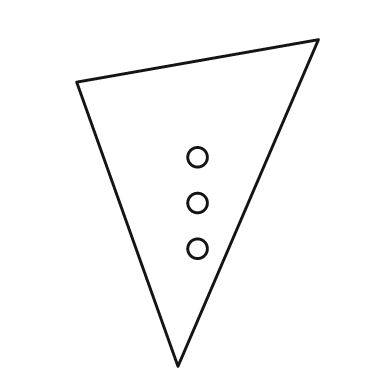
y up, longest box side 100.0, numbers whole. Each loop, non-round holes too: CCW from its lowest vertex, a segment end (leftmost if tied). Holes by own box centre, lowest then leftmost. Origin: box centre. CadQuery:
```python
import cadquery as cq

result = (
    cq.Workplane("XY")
    .moveTo(-6.0, -50.0)
    .lineTo(37.0, 50.0)
    .lineTo(-37.0, 37.0)
    .close()
    .moveTo(0.0, -14.0)
    .circle(3.0)
    .moveTo(0.0, 0.0)
    .circle(3.0)
    .moveTo(0.0, 14.0)
    .circle(3.0)
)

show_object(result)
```